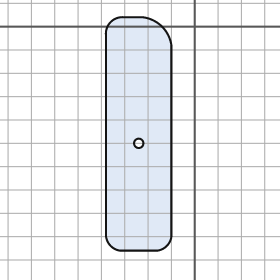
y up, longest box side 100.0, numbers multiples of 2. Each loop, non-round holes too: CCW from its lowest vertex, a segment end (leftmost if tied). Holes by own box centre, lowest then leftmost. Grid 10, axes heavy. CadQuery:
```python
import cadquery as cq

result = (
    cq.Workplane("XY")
    .moveTo(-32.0, -96.0)
    .lineTo(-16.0, -96.0)
    .threePointArc((-12.0, -94.0), (-10.0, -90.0))
    .lineTo(-10.0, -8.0)
    .threePointArc((-14.0, 0.0), (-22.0, 4.0))
    .lineTo(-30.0, 4.0)
    .threePointArc((-36.0, 2.0), (-38.0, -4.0))
    .lineTo(-38.0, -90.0)
    .threePointArc((-36.0, -94.0), (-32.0, -96.0))
    .close()
    .moveTo(-24.0, -50.0)
    .circle(2.0)
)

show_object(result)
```